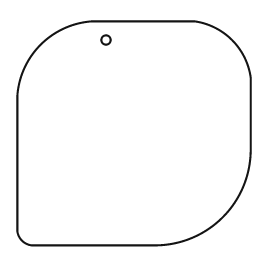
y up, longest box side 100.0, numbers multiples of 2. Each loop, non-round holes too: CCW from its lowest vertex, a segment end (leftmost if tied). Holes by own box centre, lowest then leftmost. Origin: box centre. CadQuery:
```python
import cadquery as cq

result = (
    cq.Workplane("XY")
    .moveTo(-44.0, -48.0)
    .lineTo(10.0, -48.0)
    .threePointArc((38.0, -36.0), (50.0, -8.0))
    .lineTo(50.0, 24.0)
    .threePointArc((42.0, 40.0), (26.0, 48.0))
    .lineTo(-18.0, 48.0)
    .threePointArc((-40.0, 38.0), (-50.0, 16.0))
    .lineTo(-50.0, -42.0)
    .threePointArc((-48.0, -46.0), (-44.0, -48.0))
    .close()
    .moveTo(-12.0, 40.0)
    .circle(2.0)
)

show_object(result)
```